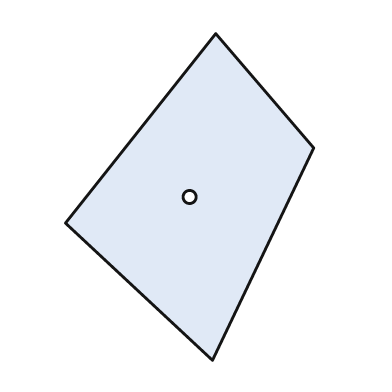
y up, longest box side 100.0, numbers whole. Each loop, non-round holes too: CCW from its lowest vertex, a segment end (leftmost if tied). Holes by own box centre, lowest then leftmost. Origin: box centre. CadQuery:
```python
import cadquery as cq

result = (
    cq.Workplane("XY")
    .moveTo(7.0, -50.0)
    .lineTo(38.0, 15.0)
    .lineTo(8.0, 50.0)
    .lineTo(-38.0, -8.0)
    .close()
    .moveTo(0.0, 0.0)
    .circle(2.0)
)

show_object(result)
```